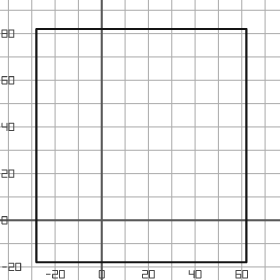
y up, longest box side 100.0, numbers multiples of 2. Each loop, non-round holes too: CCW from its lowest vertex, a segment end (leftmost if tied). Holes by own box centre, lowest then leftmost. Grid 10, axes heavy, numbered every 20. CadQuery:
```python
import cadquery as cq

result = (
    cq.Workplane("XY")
    .moveTo(-28.0, -18.0)
    .lineTo(62.0, -18.0)
    .lineTo(62.0, 82.0)
    .lineTo(-28.0, 82.0)
    .close()
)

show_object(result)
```